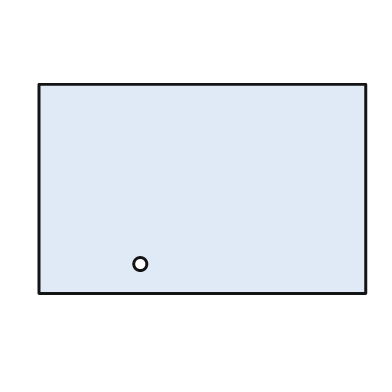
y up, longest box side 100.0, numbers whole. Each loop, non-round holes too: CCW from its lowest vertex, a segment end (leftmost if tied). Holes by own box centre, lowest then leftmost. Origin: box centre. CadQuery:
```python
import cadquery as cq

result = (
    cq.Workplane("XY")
    .moveTo(-50.0, -32.0)
    .lineTo(50.0, -32.0)
    .lineTo(50.0, 32.0)
    .lineTo(-50.0, 32.0)
    .close()
    .moveTo(-19.0, -23.0)
    .circle(2.0)
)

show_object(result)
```